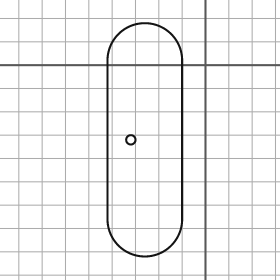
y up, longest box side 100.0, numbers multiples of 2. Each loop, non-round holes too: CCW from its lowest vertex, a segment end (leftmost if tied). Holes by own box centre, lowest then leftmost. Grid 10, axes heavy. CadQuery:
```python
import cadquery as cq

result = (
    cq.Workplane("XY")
    .moveTo(-42.0, -66.0)
    .threePointArc((-26.0, -82.0), (-10.0, -66.0))
    .lineTo(-10.0, 2.0)
    .threePointArc((-26.0, 18.0), (-42.0, 2.0))
    .close()
    .moveTo(-32.0, -32.0)
    .circle(2.0)
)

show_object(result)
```